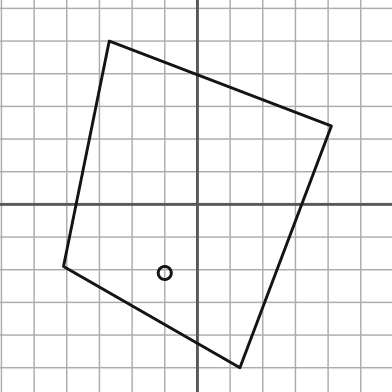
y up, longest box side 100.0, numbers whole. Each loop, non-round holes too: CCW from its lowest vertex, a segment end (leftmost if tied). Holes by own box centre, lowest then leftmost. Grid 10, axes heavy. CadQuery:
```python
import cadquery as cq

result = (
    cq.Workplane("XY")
    .moveTo(13.0, -50.0)
    .lineTo(41.0, 24.0)
    .lineTo(-27.0, 50.0)
    .lineTo(-41.0, -19.0)
    .close()
    .moveTo(-10.0, -21.0)
    .circle(2.0)
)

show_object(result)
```